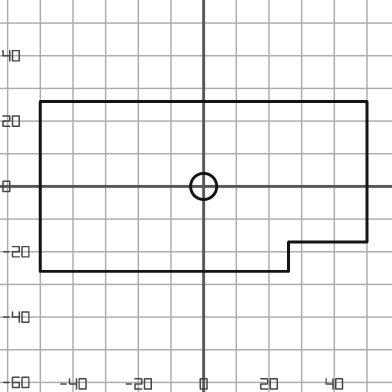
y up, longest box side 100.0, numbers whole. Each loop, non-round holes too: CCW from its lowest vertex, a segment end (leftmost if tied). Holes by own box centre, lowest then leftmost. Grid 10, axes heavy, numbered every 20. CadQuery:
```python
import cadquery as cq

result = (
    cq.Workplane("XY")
    .moveTo(-50.0, -26.0)
    .lineTo(26.0, -26.0)
    .lineTo(26.0, -17.0)
    .lineTo(50.0, -17.0)
    .lineTo(50.0, 26.0)
    .lineTo(-50.0, 26.0)
    .close()
    .moveTo(0.0, 0.0)
    .circle(4.0)
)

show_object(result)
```